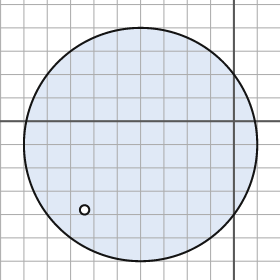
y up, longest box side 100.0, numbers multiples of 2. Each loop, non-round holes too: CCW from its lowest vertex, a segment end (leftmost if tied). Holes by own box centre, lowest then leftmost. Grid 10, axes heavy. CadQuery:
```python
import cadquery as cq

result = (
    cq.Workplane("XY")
    .moveTo(-40.0, -10.0)
    .circle(50.0)
    .moveTo(-64.0, -38.0)
    .circle(2.0)
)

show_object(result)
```